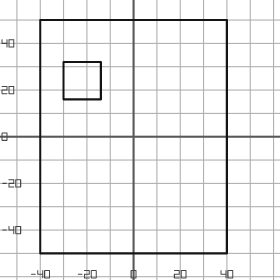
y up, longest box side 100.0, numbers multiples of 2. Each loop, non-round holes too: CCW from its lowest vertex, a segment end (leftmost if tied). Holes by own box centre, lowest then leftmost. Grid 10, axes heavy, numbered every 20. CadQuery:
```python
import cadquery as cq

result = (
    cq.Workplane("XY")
    .moveTo(-40.0, -50.0)
    .lineTo(40.0, -50.0)
    .lineTo(40.0, 50.0)
    .lineTo(-40.0, 50.0)
    .close()
    .moveTo(-30.0, 16.0)
    .lineTo(-14.0, 16.0)
    .lineTo(-14.0, 32.0)
    .lineTo(-30.0, 32.0)
    .close()
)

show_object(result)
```